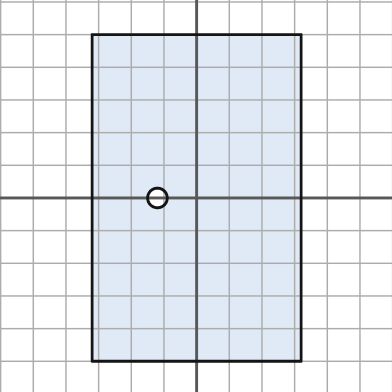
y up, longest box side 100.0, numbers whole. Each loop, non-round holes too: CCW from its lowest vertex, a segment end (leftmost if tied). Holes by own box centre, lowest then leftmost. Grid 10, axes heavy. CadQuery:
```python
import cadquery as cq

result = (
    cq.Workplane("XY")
    .moveTo(-32.0, -50.0)
    .lineTo(32.0, -50.0)
    .lineTo(32.0, 50.0)
    .lineTo(-32.0, 50.0)
    .close()
    .moveTo(-12.0, 0.0)
    .circle(3.0)
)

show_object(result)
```